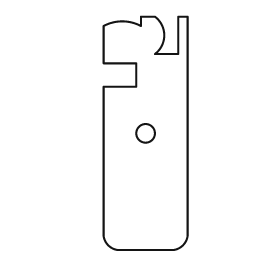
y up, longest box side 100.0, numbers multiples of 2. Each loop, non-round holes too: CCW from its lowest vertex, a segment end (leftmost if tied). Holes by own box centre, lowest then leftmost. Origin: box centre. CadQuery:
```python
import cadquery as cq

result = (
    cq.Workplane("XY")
    .moveTo(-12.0, -50.0)
    .lineTo(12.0, -50.0)
    .threePointArc((16.0, -48.0), (18.0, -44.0))
    .lineTo(18.0, 50.0)
    .lineTo(14.0, 50.0)
    .lineTo(14.0, 34.0)
    .lineTo(4.0, 34.0)
    .threePointArc((8.0, 42.0), (4.0, 50.0))
    .lineTo(-2.0, 50.0)
    .lineTo(-2.0, 46.0)
    .threePointArc((-10.0, 48.0), (-18.0, 46.0))
    .lineTo(-18.0, 30.0)
    .lineTo(-4.0, 30.0)
    .lineTo(-4.0, 20.0)
    .lineTo(-18.0, 20.0)
    .lineTo(-18.0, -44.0)
    .threePointArc((-16.0, -48.0), (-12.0, -50.0))
    .close()
    .moveTo(0.0, 0.0)
    .circle(4.0)
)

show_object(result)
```